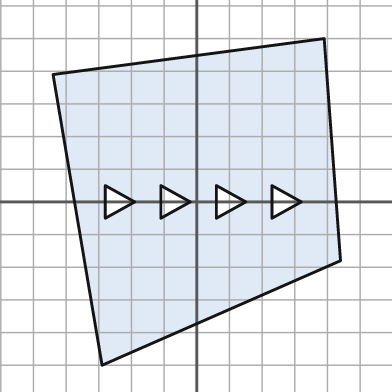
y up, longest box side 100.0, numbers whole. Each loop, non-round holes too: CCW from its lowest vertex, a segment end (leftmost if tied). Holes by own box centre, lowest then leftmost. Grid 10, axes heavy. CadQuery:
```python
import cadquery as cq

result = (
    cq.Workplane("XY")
    .moveTo(-29.0, -50.0)
    .lineTo(44.0, -18.0)
    .lineTo(39.0, 50.0)
    .lineTo(-44.0, 39.0)
    .close()
    .moveTo(-28.0, -5.0)
    .lineTo(-19.0, 0.0)
    .lineTo(-28.0, 5.0)
    .close()
    .moveTo(-11.0, -5.0)
    .lineTo(-2.0, 0.0)
    .lineTo(-11.0, 5.0)
    .close()
    .moveTo(6.0, -5.0)
    .lineTo(15.0, 0.0)
    .lineTo(6.0, 5.0)
    .close()
    .moveTo(23.0, -5.0)
    .lineTo(32.0, 0.0)
    .lineTo(23.0, 5.0)
    .close()
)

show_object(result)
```